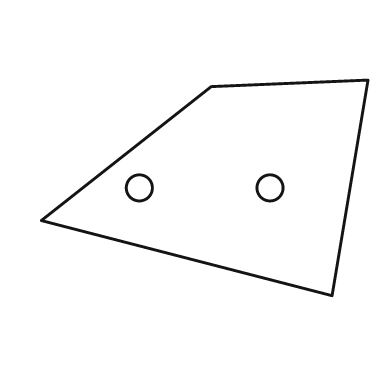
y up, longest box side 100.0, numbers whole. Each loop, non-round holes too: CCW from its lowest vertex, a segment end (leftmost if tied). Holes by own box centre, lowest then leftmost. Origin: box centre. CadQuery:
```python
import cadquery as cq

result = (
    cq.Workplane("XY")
    .moveTo(39.0, -33.0)
    .lineTo(50.0, 33.0)
    .lineTo(2.0, 31.0)
    .lineTo(-50.0, -10.0)
    .close()
    .moveTo(-20.0, 0.0)
    .circle(4.0)
    .moveTo(20.0, 0.0)
    .circle(4.0)
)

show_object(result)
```